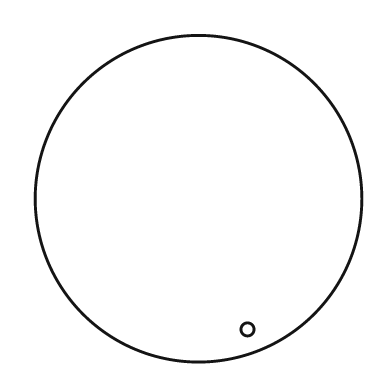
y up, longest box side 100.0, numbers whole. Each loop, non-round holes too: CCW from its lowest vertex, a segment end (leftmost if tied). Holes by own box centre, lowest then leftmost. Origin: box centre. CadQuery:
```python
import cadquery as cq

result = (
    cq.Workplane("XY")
    .moveTo(0.0, 0.0)
    .circle(50.0)
    .moveTo(15.0, -40.0)
    .circle(2.0)
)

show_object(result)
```